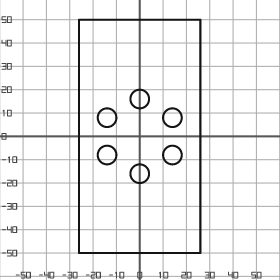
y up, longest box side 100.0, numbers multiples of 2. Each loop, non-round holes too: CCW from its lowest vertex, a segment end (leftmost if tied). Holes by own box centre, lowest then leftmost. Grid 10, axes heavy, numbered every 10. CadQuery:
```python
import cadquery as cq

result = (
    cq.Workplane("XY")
    .moveTo(-26.0, -50.0)
    .lineTo(26.0, -50.0)
    .lineTo(26.0, 50.0)
    .lineTo(-26.0, 50.0)
    .close()
    .moveTo(0.0, -16.0)
    .circle(4.0)
    .moveTo(-14.0, -8.0)
    .circle(4.0)
    .moveTo(14.0, -8.0)
    .circle(4.0)
    .moveTo(-14.0, 8.0)
    .circle(4.0)
    .moveTo(14.0, 8.0)
    .circle(4.0)
    .moveTo(0.0, 16.0)
    .circle(4.0)
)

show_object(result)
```